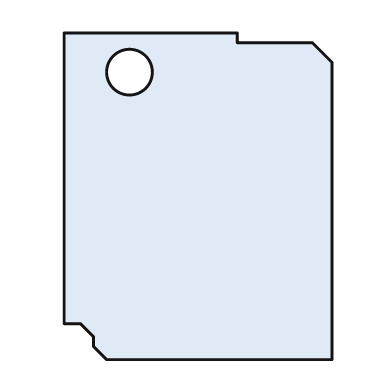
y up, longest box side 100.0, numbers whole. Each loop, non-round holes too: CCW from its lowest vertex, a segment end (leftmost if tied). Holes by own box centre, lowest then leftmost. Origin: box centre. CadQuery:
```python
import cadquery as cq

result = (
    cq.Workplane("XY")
    .moveTo(-28.0, -50.0)
    .lineTo(41.0, -50.0)
    .lineTo(41.0, 41.0)
    .lineTo(35.0, 47.0)
    .lineTo(12.0, 47.0)
    .lineTo(12.0, 50.0)
    .lineTo(-41.0, 50.0)
    .lineTo(-41.0, -39.0)
    .lineTo(-36.0, -39.0)
    .lineTo(-32.0, -43.0)
    .lineTo(-32.0, -46.0)
    .close()
    .moveTo(-21.0, 38.0)
    .circle(7.0)
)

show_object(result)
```